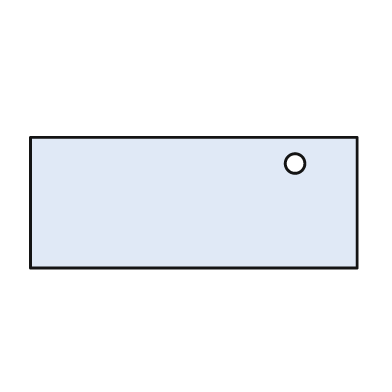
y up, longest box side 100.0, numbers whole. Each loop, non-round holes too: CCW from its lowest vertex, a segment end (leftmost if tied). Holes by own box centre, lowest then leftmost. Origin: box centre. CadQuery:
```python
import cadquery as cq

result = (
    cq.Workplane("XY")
    .moveTo(-50.0, -20.0)
    .lineTo(50.0, -20.0)
    .lineTo(50.0, 20.0)
    .lineTo(-50.0, 20.0)
    .close()
    .moveTo(31.0, 12.0)
    .circle(3.0)
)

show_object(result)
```